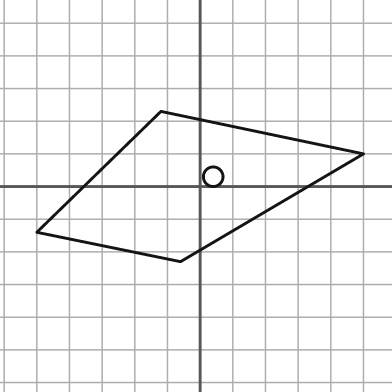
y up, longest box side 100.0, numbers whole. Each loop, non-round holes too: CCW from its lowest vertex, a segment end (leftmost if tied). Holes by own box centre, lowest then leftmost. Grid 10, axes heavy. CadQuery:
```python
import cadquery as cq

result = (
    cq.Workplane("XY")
    .moveTo(-6.0, -23.0)
    .lineTo(50.0, 10.0)
    .lineTo(-12.0, 23.0)
    .lineTo(-50.0, -14.0)
    .close()
    .moveTo(4.0, 3.0)
    .circle(3.0)
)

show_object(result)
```